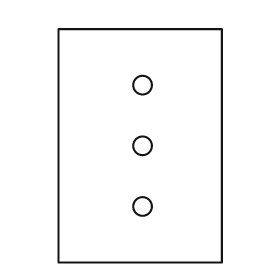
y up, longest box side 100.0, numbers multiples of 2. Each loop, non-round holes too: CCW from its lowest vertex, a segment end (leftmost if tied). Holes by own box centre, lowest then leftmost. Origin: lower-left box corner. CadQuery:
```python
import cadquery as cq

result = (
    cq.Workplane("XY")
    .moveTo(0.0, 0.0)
    .lineTo(70.0, 0.0)
    .lineTo(70.0, 100.0)
    .lineTo(0.0, 100.0)
    .close()
    .moveTo(36.0, 24.0)
    .circle(4.0)
    .moveTo(36.0, 50.0)
    .circle(4.0)
    .moveTo(36.0, 76.0)
    .circle(4.0)
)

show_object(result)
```